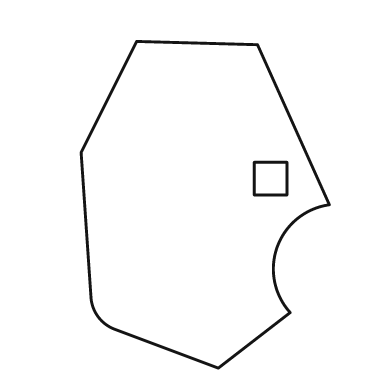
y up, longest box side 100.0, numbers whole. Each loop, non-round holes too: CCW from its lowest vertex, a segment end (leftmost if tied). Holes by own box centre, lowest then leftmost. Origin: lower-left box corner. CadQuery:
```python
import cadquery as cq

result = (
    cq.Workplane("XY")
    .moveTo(42.0, 0.0)
    .lineTo(64.0, 17.0)
    .threePointArc((60.0, 37.0), (76.0, 50.0))
    .lineTo(54.0, 99.0)
    .lineTo(17.0, 100.0)
    .lineTo(0.0, 66.0)
    .lineTo(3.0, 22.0)
    .threePointArc((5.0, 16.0), (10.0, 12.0))
    .close()
    .moveTo(53.0, 53.0)
    .lineTo(63.0, 53.0)
    .lineTo(63.0, 63.0)
    .lineTo(53.0, 63.0)
    .close()
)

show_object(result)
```